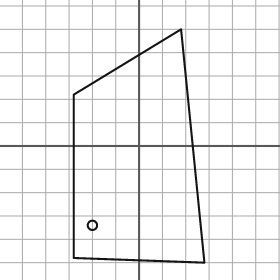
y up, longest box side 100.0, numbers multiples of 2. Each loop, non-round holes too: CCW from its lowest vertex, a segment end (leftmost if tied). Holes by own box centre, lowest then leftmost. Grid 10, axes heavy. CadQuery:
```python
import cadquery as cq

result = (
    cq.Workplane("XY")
    .moveTo(28.0, -50.0)
    .lineTo(18.0, 50.0)
    .lineTo(-28.0, 22.0)
    .lineTo(-28.0, -48.0)
    .close()
    .moveTo(-20.0, -34.0)
    .circle(2.0)
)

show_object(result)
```